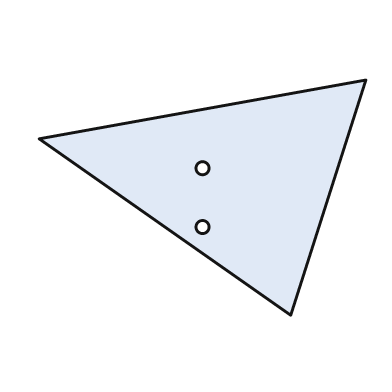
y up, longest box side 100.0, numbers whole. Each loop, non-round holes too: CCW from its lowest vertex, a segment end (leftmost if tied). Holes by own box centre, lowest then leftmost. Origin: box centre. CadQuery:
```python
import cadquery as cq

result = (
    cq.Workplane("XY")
    .moveTo(27.0, -36.0)
    .lineTo(50.0, 36.0)
    .lineTo(-50.0, 18.0)
    .close()
    .moveTo(0.0, -9.0)
    .circle(2.0)
    .moveTo(0.0, 9.0)
    .circle(2.0)
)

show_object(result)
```